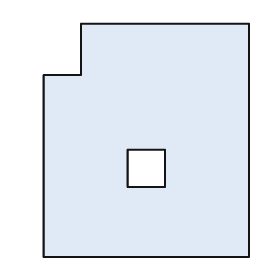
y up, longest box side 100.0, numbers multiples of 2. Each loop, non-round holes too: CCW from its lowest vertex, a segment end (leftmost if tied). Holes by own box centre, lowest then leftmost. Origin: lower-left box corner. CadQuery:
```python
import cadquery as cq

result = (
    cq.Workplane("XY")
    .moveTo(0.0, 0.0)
    .lineTo(88.0, 0.0)
    .lineTo(88.0, 100.0)
    .lineTo(16.0, 100.0)
    .lineTo(16.0, 78.0)
    .lineTo(0.0, 78.0)
    .close()
    .moveTo(36.0, 30.0)
    .lineTo(52.0, 30.0)
    .lineTo(52.0, 46.0)
    .lineTo(36.0, 46.0)
    .close()
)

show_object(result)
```